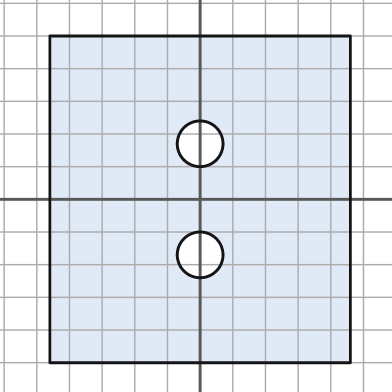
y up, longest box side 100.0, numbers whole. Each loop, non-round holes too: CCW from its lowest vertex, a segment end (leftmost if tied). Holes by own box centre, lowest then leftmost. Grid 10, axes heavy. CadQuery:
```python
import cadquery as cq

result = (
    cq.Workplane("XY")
    .moveTo(-46.0, -50.0)
    .lineTo(46.0, -50.0)
    .lineTo(46.0, 50.0)
    .lineTo(-46.0, 50.0)
    .close()
    .moveTo(0.0, -17.0)
    .circle(7.0)
    .moveTo(0.0, 17.0)
    .circle(7.0)
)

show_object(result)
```